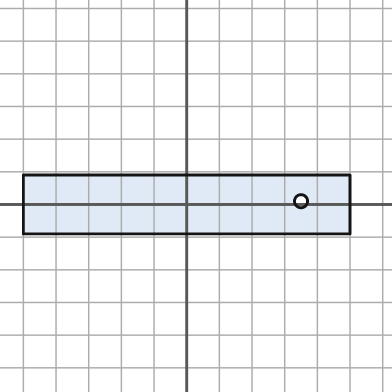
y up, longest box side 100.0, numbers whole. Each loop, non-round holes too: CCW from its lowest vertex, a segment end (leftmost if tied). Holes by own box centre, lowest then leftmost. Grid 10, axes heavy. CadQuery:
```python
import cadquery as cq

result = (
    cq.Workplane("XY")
    .moveTo(-50.0, -9.0)
    .lineTo(50.0, -9.0)
    .lineTo(50.0, 9.0)
    .lineTo(-50.0, 9.0)
    .close()
    .moveTo(35.0, 1.0)
    .circle(2.0)
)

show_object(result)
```